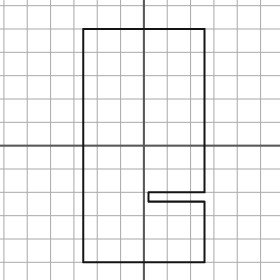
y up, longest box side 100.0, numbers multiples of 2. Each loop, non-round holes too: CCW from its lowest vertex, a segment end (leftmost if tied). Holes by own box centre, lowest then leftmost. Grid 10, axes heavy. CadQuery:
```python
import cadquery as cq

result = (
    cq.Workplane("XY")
    .moveTo(-26.0, -50.0)
    .lineTo(26.0, -50.0)
    .lineTo(26.0, -24.0)
    .lineTo(2.0, -24.0)
    .lineTo(2.0, -20.0)
    .lineTo(26.0, -20.0)
    .lineTo(26.0, 50.0)
    .lineTo(-26.0, 50.0)
    .close()
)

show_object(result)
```